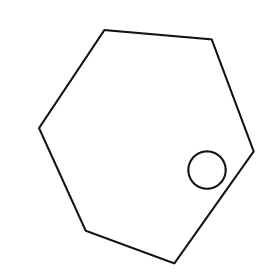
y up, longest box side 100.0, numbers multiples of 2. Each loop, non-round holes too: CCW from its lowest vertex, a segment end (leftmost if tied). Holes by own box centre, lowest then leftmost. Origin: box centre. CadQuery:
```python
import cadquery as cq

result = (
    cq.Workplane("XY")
    .moveTo(12.0, -50.0)
    .lineTo(46.0, -2.0)
    .lineTo(28.0, 46.0)
    .lineTo(-18.0, 50.0)
    .lineTo(-46.0, 8.0)
    .lineTo(-26.0, -36.0)
    .close()
    .moveTo(26.0, -10.0)
    .circle(8.0)
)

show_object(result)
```